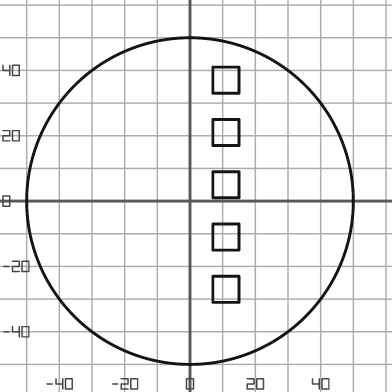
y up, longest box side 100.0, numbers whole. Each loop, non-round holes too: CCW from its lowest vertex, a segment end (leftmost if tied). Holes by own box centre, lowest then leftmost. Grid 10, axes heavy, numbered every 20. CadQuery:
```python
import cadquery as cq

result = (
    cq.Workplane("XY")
    .moveTo(0.0, 0.0)
    .circle(50.0)
    .moveTo(7.0, -31.0)
    .lineTo(15.0, -31.0)
    .lineTo(15.0, -23.0)
    .lineTo(7.0, -23.0)
    .close()
    .moveTo(7.0, -15.0)
    .lineTo(15.0, -15.0)
    .lineTo(15.0, -7.0)
    .lineTo(7.0, -7.0)
    .close()
    .moveTo(7.0, 1.0)
    .lineTo(15.0, 1.0)
    .lineTo(15.0, 9.0)
    .lineTo(7.0, 9.0)
    .close()
    .moveTo(7.0, 17.0)
    .lineTo(15.0, 17.0)
    .lineTo(15.0, 25.0)
    .lineTo(7.0, 25.0)
    .close()
    .moveTo(7.0, 33.0)
    .lineTo(15.0, 33.0)
    .lineTo(15.0, 41.0)
    .lineTo(7.0, 41.0)
    .close()
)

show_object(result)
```